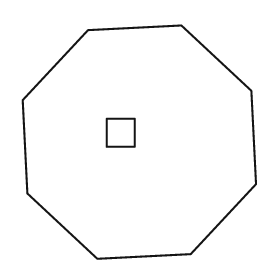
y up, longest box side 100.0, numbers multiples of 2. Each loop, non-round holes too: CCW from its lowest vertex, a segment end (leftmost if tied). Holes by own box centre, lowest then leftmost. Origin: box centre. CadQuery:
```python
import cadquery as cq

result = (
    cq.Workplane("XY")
    .moveTo(-18.0, -50.0)
    .lineTo(22.0, -48.0)
    .lineTo(50.0, -18.0)
    .lineTo(48.0, 22.0)
    .lineTo(18.0, 50.0)
    .lineTo(-22.0, 48.0)
    .lineTo(-50.0, 18.0)
    .lineTo(-48.0, -22.0)
    .close()
    .moveTo(-14.0, -2.0)
    .lineTo(-2.0, -2.0)
    .lineTo(-2.0, 10.0)
    .lineTo(-14.0, 10.0)
    .close()
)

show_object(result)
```